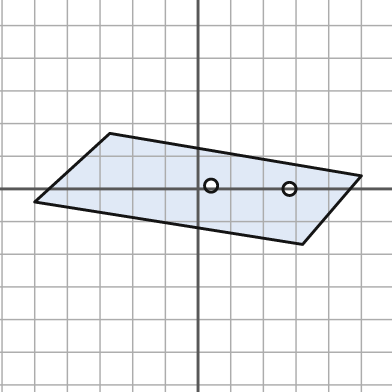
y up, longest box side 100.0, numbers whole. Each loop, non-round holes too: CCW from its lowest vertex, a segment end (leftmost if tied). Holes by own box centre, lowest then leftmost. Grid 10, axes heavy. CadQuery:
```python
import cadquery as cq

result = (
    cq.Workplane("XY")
    .moveTo(32.0, -17.0)
    .lineTo(50.0, 4.0)
    .lineTo(-27.0, 17.0)
    .lineTo(-50.0, -4.0)
    .close()
    .moveTo(28.0, 0.0)
    .circle(2.0)
    .moveTo(4.0, 1.0)
    .circle(2.0)
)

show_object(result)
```